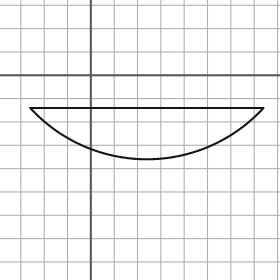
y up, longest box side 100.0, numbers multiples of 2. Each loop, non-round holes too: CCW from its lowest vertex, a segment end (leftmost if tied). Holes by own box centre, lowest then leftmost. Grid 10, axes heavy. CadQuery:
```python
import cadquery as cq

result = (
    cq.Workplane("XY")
    .moveTo(-26.0, -14.0)
    .threePointArc((24.0, -36.0), (74.0, -14.0))
    .close()
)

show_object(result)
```